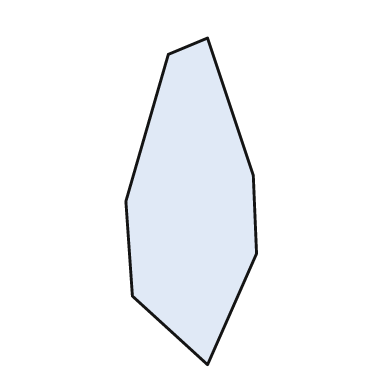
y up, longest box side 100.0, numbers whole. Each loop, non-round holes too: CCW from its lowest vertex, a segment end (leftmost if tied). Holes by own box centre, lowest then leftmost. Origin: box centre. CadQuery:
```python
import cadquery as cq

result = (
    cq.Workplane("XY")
    .moveTo(5.0, -50.0)
    .lineTo(20.0, -16.0)
    .lineTo(19.0, 8.0)
    .lineTo(5.0, 50.0)
    .lineTo(-7.0, 45.0)
    .lineTo(-20.0, 0.0)
    .lineTo(-18.0, -29.0)
    .close()
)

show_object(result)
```